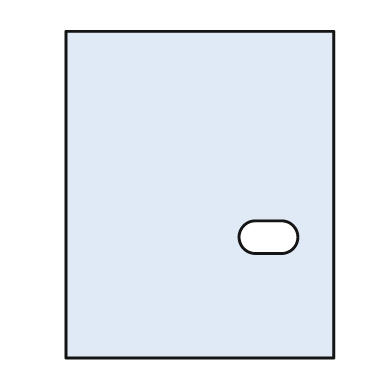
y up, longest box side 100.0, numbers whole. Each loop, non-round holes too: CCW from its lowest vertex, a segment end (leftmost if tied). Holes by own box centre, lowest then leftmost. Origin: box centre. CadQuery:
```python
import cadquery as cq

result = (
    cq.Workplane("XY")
    .moveTo(-41.0, -50.0)
    .lineTo(41.0, -50.0)
    .lineTo(41.0, 50.0)
    .lineTo(-41.0, 50.0)
    .close()
    .moveTo(17.0, -18.0)
    .lineTo(25.0, -18.0)
    .threePointArc((30.0, -13.0), (25.0, -8.0))
    .lineTo(17.0, -8.0)
    .threePointArc((12.0, -13.0), (17.0, -18.0))
    .close()
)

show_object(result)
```